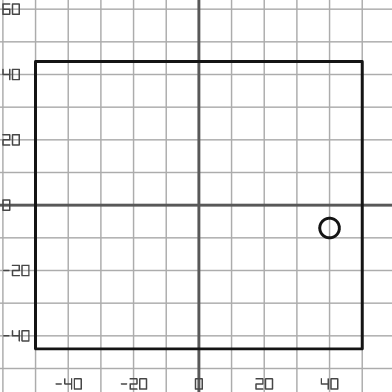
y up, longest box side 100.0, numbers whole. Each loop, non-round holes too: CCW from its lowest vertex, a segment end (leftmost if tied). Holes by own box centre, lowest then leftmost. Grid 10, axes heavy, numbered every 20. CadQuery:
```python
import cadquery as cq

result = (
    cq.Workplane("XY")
    .moveTo(-50.0, -44.0)
    .lineTo(50.0, -44.0)
    .lineTo(50.0, 44.0)
    .lineTo(-50.0, 44.0)
    .close()
    .moveTo(40.0, -7.0)
    .circle(3.0)
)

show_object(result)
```